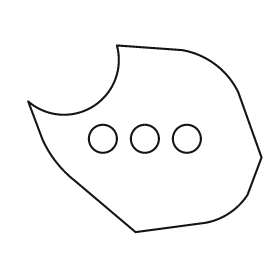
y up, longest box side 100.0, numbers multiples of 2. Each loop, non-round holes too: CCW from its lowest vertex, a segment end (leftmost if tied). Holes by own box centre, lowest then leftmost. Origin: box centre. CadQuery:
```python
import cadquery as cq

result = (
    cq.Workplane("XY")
    .moveTo(-4.0, -40.0)
    .lineTo(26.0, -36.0)
    .threePointArc((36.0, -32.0), (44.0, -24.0))
    .lineTo(50.0, -8.0)
    .lineTo(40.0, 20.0)
    .threePointArc((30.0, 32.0), (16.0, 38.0))
    .lineTo(-12.0, 40.0)
    .threePointArc((-22.0, 14.0), (-50.0, 16.0))
    .lineTo(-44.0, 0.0)
    .threePointArc((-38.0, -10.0), (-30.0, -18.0))
    .close()
    .moveTo(-18.0, 0.0)
    .circle(6.0)
    .moveTo(0.0, 0.0)
    .circle(6.0)
    .moveTo(18.0, 0.0)
    .circle(6.0)
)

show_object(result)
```